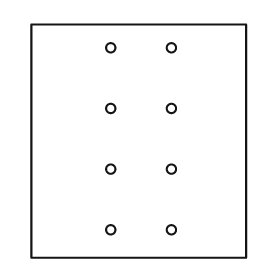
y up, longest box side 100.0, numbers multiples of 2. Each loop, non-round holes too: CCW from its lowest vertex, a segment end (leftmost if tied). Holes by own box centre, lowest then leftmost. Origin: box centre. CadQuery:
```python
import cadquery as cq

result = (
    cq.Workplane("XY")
    .moveTo(-46.0, -50.0)
    .lineTo(46.0, -50.0)
    .lineTo(46.0, 50.0)
    .lineTo(-46.0, 50.0)
    .close()
    .moveTo(-12.0, -38.0)
    .circle(2.0)
    .moveTo(14.0, -38.0)
    .circle(2.0)
    .moveTo(-12.0, -12.0)
    .circle(2.0)
    .moveTo(14.0, -12.0)
    .circle(2.0)
    .moveTo(-12.0, 14.0)
    .circle(2.0)
    .moveTo(14.0, 14.0)
    .circle(2.0)
    .moveTo(-12.0, 40.0)
    .circle(2.0)
    .moveTo(14.0, 40.0)
    .circle(2.0)
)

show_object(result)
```